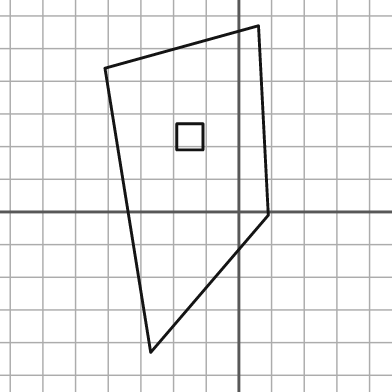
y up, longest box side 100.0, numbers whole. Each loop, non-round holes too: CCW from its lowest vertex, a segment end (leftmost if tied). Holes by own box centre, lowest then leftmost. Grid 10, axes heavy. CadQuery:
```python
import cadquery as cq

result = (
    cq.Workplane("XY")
    .moveTo(-27.0, -43.0)
    .lineTo(9.0, -1.0)
    .lineTo(6.0, 57.0)
    .lineTo(-41.0, 44.0)
    .close()
    .moveTo(-19.0, 19.0)
    .lineTo(-11.0, 19.0)
    .lineTo(-11.0, 27.0)
    .lineTo(-19.0, 27.0)
    .close()
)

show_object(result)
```